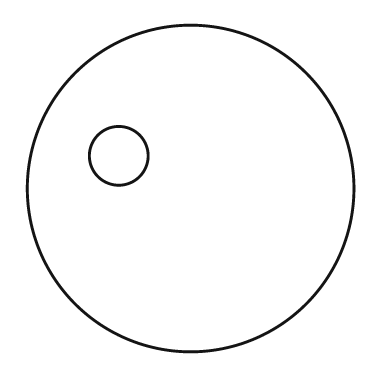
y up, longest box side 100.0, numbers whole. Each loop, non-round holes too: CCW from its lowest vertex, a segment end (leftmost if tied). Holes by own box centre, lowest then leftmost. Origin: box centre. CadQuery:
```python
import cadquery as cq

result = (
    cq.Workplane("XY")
    .moveTo(0.0, 0.0)
    .circle(50.0)
    .moveTo(-22.0, 10.0)
    .circle(9.0)
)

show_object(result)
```